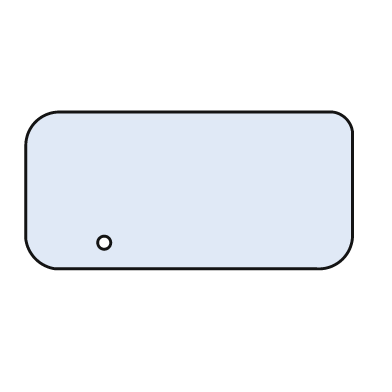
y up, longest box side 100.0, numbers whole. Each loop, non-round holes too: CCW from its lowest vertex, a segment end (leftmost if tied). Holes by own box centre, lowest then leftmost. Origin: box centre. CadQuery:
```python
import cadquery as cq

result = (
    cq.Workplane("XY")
    .moveTo(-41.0, -24.0)
    .lineTo(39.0, -24.0)
    .threePointArc((47.0, -21.0), (50.0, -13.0))
    .lineTo(50.0, 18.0)
    .threePointArc((48.0, 22.0), (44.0, 24.0))
    .lineTo(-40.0, 24.0)
    .threePointArc((-47.0, 21.0), (-50.0, 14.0))
    .lineTo(-50.0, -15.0)
    .threePointArc((-47.0, -21.0), (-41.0, -24.0))
    .close()
    .moveTo(-26.0, -16.0)
    .circle(2.0)
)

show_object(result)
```